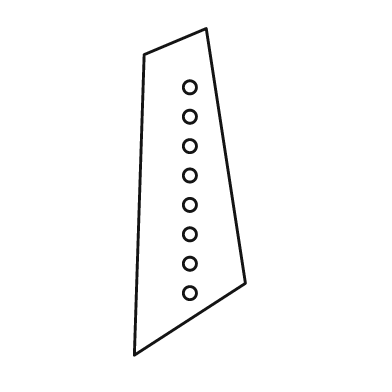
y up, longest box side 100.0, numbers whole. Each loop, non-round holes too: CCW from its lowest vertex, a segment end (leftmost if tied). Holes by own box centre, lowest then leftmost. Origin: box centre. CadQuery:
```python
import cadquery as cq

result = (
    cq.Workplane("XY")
    .moveTo(-17.0, -50.0)
    .lineTo(17.0, -28.0)
    .lineTo(5.0, 50.0)
    .lineTo(-14.0, 42.0)
    .close()
    .moveTo(0.0, -31.0)
    .circle(2.0)
    .moveTo(0.0, -22.0)
    .circle(2.0)
    .moveTo(0.0, -13.0)
    .circle(2.0)
    .moveTo(0.0, -4.0)
    .circle(2.0)
    .moveTo(0.0, 5.0)
    .circle(2.0)
    .moveTo(0.0, 14.0)
    .circle(2.0)
    .moveTo(0.0, 23.0)
    .circle(2.0)
    .moveTo(0.0, 32.0)
    .circle(2.0)
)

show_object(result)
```